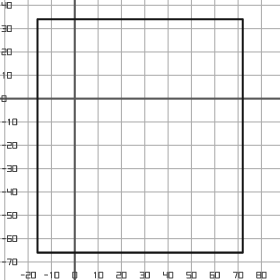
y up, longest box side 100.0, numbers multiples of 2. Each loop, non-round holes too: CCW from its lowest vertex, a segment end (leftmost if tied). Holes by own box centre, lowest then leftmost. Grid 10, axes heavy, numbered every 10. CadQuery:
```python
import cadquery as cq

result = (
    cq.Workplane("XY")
    .moveTo(-16.0, -66.0)
    .lineTo(72.0, -66.0)
    .lineTo(72.0, 34.0)
    .lineTo(-16.0, 34.0)
    .close()
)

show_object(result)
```